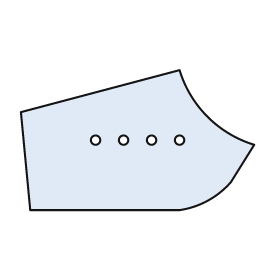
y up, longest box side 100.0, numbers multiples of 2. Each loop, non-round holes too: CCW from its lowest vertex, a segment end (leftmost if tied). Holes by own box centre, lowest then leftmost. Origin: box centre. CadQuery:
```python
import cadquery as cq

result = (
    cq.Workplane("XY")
    .moveTo(-46.0, -30.0)
    .lineTo(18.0, -30.0)
    .threePointArc((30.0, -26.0), (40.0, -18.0))
    .lineTo(50.0, -2.0)
    .threePointArc((30.0, 10.0), (18.0, 30.0))
    .lineTo(-50.0, 12.0)
    .close()
    .moveTo(-18.0, 0.0)
    .circle(2.0)
    .moveTo(-6.0, 0.0)
    .circle(2.0)
    .moveTo(6.0, 0.0)
    .circle(2.0)
    .moveTo(18.0, 0.0)
    .circle(2.0)
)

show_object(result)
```